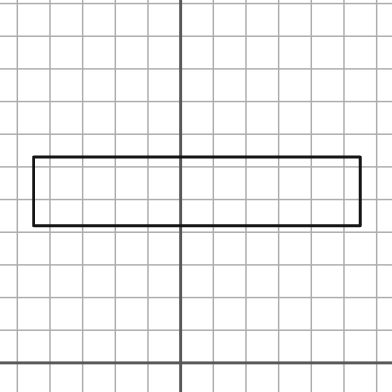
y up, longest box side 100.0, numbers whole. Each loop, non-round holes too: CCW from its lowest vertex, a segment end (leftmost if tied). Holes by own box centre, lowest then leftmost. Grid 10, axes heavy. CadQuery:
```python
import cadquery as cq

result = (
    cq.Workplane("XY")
    .moveTo(-45.0, 42.0)
    .lineTo(55.0, 42.0)
    .lineTo(55.0, 63.0)
    .lineTo(-45.0, 63.0)
    .close()
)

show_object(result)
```